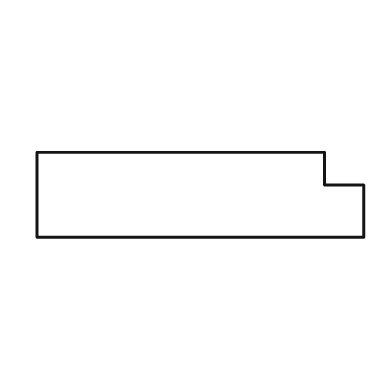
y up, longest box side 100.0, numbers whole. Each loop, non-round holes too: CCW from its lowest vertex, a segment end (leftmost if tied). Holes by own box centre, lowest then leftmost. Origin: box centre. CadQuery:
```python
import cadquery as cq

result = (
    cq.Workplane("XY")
    .moveTo(-50.0, -13.0)
    .lineTo(50.0, -13.0)
    .lineTo(50.0, 3.0)
    .lineTo(38.0, 3.0)
    .lineTo(38.0, 13.0)
    .lineTo(-50.0, 13.0)
    .close()
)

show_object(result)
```